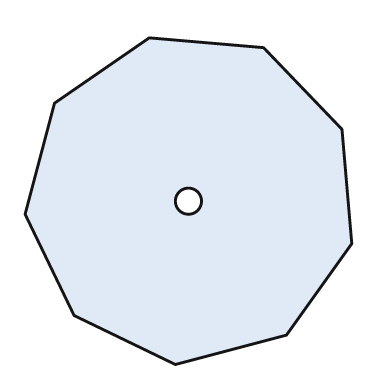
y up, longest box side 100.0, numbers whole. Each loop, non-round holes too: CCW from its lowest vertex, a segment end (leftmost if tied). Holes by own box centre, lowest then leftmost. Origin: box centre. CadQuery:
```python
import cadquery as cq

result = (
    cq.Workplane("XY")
    .moveTo(-4.0, -50.0)
    .lineTo(30.0, -41.0)
    .lineTo(50.0, -13.0)
    .lineTo(47.0, 22.0)
    .lineTo(23.0, 47.0)
    .lineTo(-12.0, 50.0)
    .lineTo(-41.0, 30.0)
    .lineTo(-50.0, -4.0)
    .lineTo(-35.0, -35.0)
    .close()
    .moveTo(0.0, 0.0)
    .circle(4.0)
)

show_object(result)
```